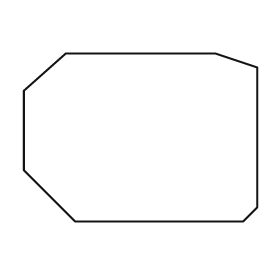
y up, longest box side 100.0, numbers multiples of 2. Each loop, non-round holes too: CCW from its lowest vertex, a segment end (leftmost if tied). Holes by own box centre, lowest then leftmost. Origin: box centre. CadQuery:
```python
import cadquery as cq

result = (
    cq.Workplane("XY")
    .moveTo(-28.0, -36.0)
    .lineTo(44.0, -36.0)
    .lineTo(50.0, -30.0)
    .lineTo(50.0, 30.0)
    .lineTo(32.0, 36.0)
    .lineTo(-32.0, 36.0)
    .lineTo(-50.0, 20.0)
    .lineTo(-50.0, -14.0)
    .close()
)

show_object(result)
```